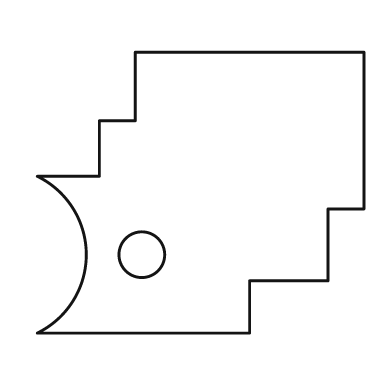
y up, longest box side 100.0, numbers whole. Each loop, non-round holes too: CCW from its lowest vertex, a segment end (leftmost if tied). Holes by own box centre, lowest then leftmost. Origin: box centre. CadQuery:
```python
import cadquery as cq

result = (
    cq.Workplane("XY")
    .moveTo(-50.0, -43.0)
    .lineTo(15.0, -43.0)
    .lineTo(15.0, -27.0)
    .lineTo(39.0, -27.0)
    .lineTo(39.0, -5.0)
    .lineTo(50.0, -5.0)
    .lineTo(50.0, 43.0)
    .lineTo(-20.0, 43.0)
    .lineTo(-20.0, 22.0)
    .lineTo(-31.0, 22.0)
    .lineTo(-31.0, 5.0)
    .lineTo(-50.0, 5.0)
    .threePointArc((-35.0, -19.0), (-50.0, -43.0))
    .close()
    .moveTo(-18.0, -19.0)
    .circle(7.0)
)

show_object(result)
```